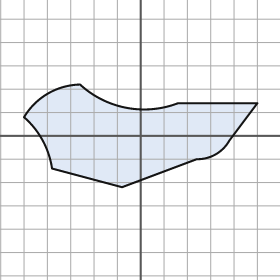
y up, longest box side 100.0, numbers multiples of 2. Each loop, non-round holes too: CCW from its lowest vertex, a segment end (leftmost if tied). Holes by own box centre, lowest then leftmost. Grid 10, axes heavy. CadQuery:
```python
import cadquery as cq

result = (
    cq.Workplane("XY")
    .moveTo(-8.0, -22.0)
    .lineTo(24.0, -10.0)
    .threePointArc((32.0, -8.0), (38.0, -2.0))
    .lineTo(50.0, 14.0)
    .lineTo(16.0, 14.0)
    .threePointArc((-6.0, 12.0), (-26.0, 22.0))
    .threePointArc((-40.0, 18.0), (-50.0, 8.0))
    .threePointArc((-42.0, -2.0), (-38.0, -14.0))
    .close()
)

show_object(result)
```